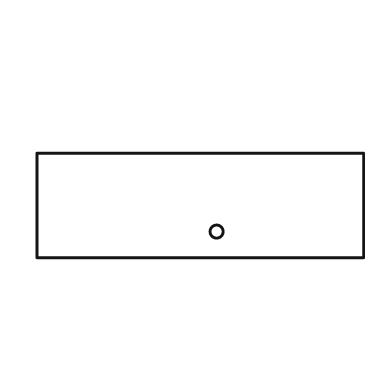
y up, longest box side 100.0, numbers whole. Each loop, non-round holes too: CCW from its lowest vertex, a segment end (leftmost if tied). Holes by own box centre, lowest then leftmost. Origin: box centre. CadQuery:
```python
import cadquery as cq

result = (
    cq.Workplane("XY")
    .moveTo(-50.0, -16.0)
    .lineTo(50.0, -16.0)
    .lineTo(50.0, 16.0)
    .lineTo(-50.0, 16.0)
    .close()
    .moveTo(5.0, -8.0)
    .circle(2.0)
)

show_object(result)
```